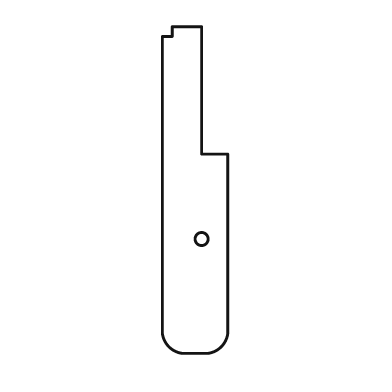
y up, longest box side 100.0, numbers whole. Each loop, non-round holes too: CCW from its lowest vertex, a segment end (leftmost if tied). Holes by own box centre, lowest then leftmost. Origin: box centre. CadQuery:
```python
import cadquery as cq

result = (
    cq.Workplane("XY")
    .moveTo(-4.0, -50.0)
    .lineTo(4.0, -50.0)
    .threePointArc((8.0, -48.0), (10.0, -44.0))
    .lineTo(10.0, 11.0)
    .lineTo(2.0, 11.0)
    .lineTo(2.0, 50.0)
    .lineTo(-7.0, 50.0)
    .lineTo(-7.0, 47.0)
    .lineTo(-10.0, 47.0)
    .lineTo(-10.0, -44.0)
    .threePointArc((-8.0, -48.0), (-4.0, -50.0))
    .close()
    .moveTo(2.0, -15.0)
    .circle(2.0)
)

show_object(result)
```